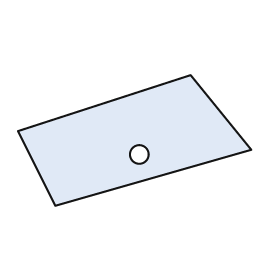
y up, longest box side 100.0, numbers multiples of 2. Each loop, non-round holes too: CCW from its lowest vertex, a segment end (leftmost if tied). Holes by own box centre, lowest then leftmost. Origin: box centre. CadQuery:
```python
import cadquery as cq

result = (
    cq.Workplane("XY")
    .moveTo(-34.0, -28.0)
    .lineTo(50.0, -4.0)
    .lineTo(24.0, 28.0)
    .lineTo(-50.0, 4.0)
    .close()
    .moveTo(2.0, -6.0)
    .circle(4.0)
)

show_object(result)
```